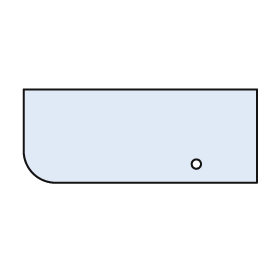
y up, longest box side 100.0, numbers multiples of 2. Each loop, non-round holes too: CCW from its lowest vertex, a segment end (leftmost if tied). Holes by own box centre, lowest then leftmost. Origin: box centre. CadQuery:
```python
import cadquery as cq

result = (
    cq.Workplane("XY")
    .moveTo(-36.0, -20.0)
    .lineTo(50.0, -20.0)
    .lineTo(50.0, 20.0)
    .lineTo(-50.0, 20.0)
    .lineTo(-50.0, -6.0)
    .threePointArc((-46.0, -16.0), (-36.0, -20.0))
    .close()
    .moveTo(24.0, -12.0)
    .circle(2.0)
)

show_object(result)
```